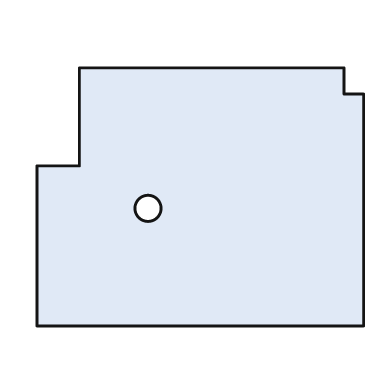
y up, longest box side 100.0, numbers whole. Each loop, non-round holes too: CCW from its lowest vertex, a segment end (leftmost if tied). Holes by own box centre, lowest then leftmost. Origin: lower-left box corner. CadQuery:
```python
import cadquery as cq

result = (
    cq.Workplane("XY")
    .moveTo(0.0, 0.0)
    .lineTo(100.0, 0.0)
    .lineTo(100.0, 71.0)
    .lineTo(94.0, 71.0)
    .lineTo(94.0, 79.0)
    .lineTo(13.0, 79.0)
    .lineTo(13.0, 49.0)
    .lineTo(0.0, 49.0)
    .close()
    .moveTo(34.0, 36.0)
    .circle(4.0)
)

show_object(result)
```